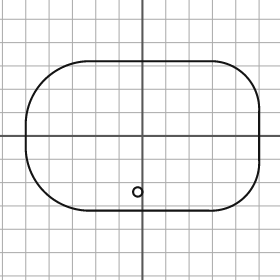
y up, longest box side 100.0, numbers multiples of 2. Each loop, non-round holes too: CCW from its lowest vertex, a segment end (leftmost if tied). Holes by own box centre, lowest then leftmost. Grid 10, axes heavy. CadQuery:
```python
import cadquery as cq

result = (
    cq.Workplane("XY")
    .moveTo(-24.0, -32.0)
    .lineTo(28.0, -32.0)
    .threePointArc((44.0, -26.0), (50.0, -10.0))
    .lineTo(50.0, 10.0)
    .threePointArc((44.0, 26.0), (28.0, 32.0))
    .lineTo(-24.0, 32.0)
    .threePointArc((-42.0, 24.0), (-50.0, 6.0))
    .lineTo(-50.0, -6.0)
    .threePointArc((-42.0, -24.0), (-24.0, -32.0))
    .close()
    .moveTo(-2.0, -24.0)
    .circle(2.0)
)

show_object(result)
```